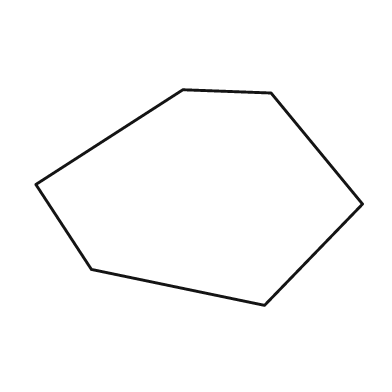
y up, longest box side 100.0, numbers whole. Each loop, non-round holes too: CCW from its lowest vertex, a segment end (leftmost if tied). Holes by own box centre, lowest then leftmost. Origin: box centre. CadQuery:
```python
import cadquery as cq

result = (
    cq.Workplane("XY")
    .moveTo(20.0, -33.0)
    .lineTo(50.0, -2.0)
    .lineTo(22.0, 32.0)
    .lineTo(-5.0, 33.0)
    .lineTo(-50.0, 4.0)
    .lineTo(-33.0, -22.0)
    .close()
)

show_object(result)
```